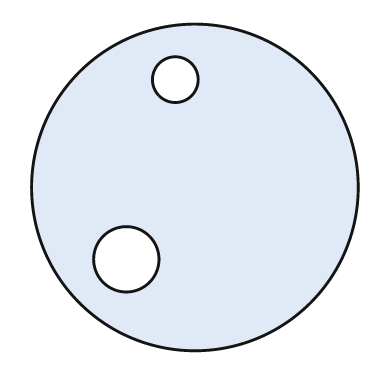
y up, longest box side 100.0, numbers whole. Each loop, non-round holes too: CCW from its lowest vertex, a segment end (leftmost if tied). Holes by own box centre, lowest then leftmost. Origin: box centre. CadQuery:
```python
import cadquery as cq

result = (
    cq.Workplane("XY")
    .moveTo(0.0, 0.0)
    .circle(50.0)
    .moveTo(-21.0, -22.0)
    .circle(10.0)
    .moveTo(-6.0, 33.0)
    .circle(7.0)
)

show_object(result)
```